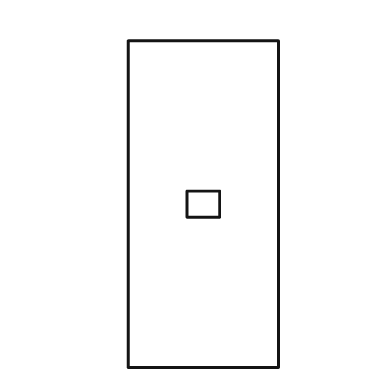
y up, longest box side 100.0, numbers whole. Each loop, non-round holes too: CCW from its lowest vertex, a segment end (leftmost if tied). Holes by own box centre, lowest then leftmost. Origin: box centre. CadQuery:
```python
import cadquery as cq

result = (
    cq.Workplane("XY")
    .moveTo(-23.0, -50.0)
    .lineTo(23.0, -50.0)
    .lineTo(23.0, 50.0)
    .lineTo(-23.0, 50.0)
    .close()
    .moveTo(-5.0, -4.0)
    .lineTo(5.0, -4.0)
    .lineTo(5.0, 4.0)
    .lineTo(-5.0, 4.0)
    .close()
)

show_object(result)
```